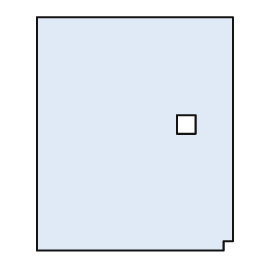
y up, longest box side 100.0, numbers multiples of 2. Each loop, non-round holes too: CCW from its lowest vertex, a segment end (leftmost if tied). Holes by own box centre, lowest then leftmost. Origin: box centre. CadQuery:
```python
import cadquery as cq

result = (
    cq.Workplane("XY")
    .moveTo(-42.0, -50.0)
    .lineTo(38.0, -50.0)
    .lineTo(38.0, -46.0)
    .lineTo(42.0, -46.0)
    .lineTo(42.0, 50.0)
    .lineTo(-42.0, 50.0)
    .close()
    .moveTo(18.0, 0.0)
    .lineTo(26.0, 0.0)
    .lineTo(26.0, 8.0)
    .lineTo(18.0, 8.0)
    .close()
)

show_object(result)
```